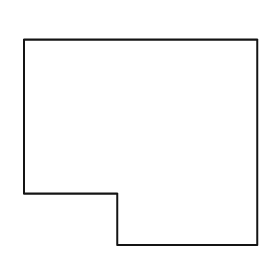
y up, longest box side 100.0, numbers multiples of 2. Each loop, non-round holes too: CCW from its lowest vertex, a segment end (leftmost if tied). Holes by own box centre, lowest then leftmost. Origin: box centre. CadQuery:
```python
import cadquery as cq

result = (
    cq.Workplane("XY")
    .moveTo(-10.0, -44.0)
    .lineTo(50.0, -44.0)
    .lineTo(50.0, 44.0)
    .lineTo(-50.0, 44.0)
    .lineTo(-50.0, -22.0)
    .lineTo(-10.0, -22.0)
    .close()
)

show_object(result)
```